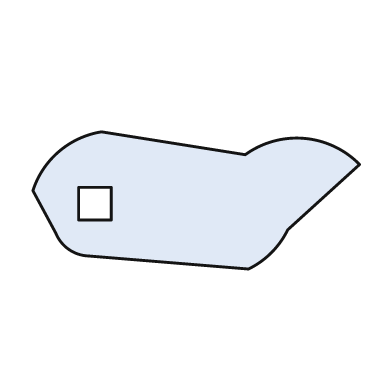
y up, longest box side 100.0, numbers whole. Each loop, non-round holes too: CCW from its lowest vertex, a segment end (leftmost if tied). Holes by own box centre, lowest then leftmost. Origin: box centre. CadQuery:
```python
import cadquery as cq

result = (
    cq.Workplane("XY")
    .moveTo(16.0, -21.0)
    .threePointArc((23.0, -16.0), (28.0, -9.0))
    .lineTo(50.0, 11.0)
    .threePointArc((33.0, 19.0), (15.0, 14.0))
    .lineTo(-29.0, 21.0)
    .threePointArc((-42.0, 15.0), (-50.0, 3.0))
    .lineTo(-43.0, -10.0)
    .threePointArc((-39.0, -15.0), (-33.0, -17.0))
    .close()
    .moveTo(-36.0, -6.0)
    .lineTo(-26.0, -6.0)
    .lineTo(-26.0, 4.0)
    .lineTo(-36.0, 4.0)
    .close()
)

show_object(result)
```